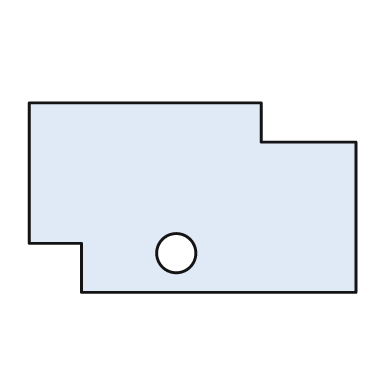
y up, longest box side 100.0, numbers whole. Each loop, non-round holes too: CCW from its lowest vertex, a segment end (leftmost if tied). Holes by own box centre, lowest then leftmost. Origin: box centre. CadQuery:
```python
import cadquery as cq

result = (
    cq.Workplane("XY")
    .moveTo(-34.0, -29.0)
    .lineTo(50.0, -29.0)
    .lineTo(50.0, 17.0)
    .lineTo(21.0, 17.0)
    .lineTo(21.0, 29.0)
    .lineTo(-50.0, 29.0)
    .lineTo(-50.0, -14.0)
    .lineTo(-34.0, -14.0)
    .close()
    .moveTo(-5.0, -17.0)
    .circle(6.0)
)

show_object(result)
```